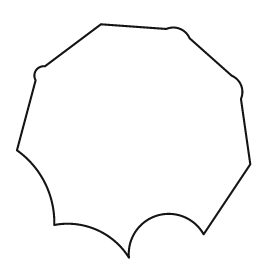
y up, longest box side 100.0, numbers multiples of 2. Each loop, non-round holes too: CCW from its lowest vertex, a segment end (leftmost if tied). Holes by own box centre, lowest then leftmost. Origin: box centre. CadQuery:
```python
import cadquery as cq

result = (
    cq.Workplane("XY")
    .moveTo(-2.0, -50.0)
    .threePointArc((10.0, -32.0), (30.0, -40.0))
    .lineTo(50.0, -10.0)
    .lineTo(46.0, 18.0)
    .threePointArc((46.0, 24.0), (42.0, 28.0))
    .lineTo(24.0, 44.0)
    .threePointArc((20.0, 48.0), (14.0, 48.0))
    .lineTo(-14.0, 50.0)
    .lineTo(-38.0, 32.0)
    .threePointArc((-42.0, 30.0), (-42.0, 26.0))
    .lineTo(-50.0, -4.0)
    .threePointArc((-38.0, -18.0), (-34.0, -36.0))
    .threePointArc((-16.0, -38.0), (-2.0, -50.0))
    .close()
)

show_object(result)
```